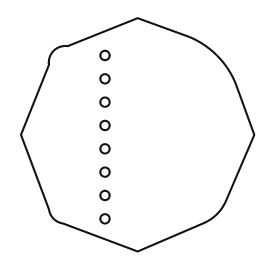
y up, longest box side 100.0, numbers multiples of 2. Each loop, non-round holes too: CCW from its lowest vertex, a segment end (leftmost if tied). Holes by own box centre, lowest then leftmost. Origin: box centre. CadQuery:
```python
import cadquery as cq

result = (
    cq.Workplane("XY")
    .moveTo(0.0, -50.0)
    .lineTo(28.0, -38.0)
    .threePointArc((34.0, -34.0), (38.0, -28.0))
    .lineTo(50.0, 0.0)
    .lineTo(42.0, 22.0)
    .threePointArc((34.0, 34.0), (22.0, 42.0))
    .lineTo(0.0, 50.0)
    .lineTo(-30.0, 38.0)
    .threePointArc((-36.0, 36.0), (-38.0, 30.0))
    .lineTo(-50.0, 0.0)
    .lineTo(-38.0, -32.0)
    .threePointArc((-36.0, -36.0), (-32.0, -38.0))
    .close()
    .moveTo(-14.0, -36.0)
    .circle(2.0)
    .moveTo(-14.0, -26.0)
    .circle(2.0)
    .moveTo(-14.0, -16.0)
    .circle(2.0)
    .moveTo(-14.0, -6.0)
    .circle(2.0)
    .moveTo(-14.0, 4.0)
    .circle(2.0)
    .moveTo(-14.0, 14.0)
    .circle(2.0)
    .moveTo(-14.0, 24.0)
    .circle(2.0)
    .moveTo(-14.0, 34.0)
    .circle(2.0)
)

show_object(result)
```